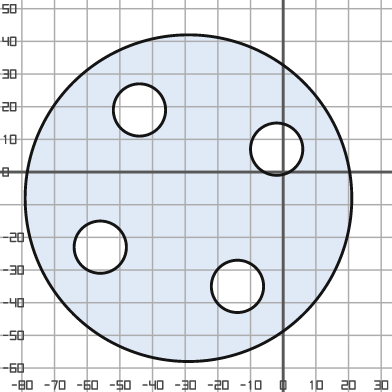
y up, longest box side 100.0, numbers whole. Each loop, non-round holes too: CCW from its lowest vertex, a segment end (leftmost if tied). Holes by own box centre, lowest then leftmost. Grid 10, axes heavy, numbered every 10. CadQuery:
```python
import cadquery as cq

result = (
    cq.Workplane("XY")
    .moveTo(-29.0, -8.0)
    .circle(50.0)
    .moveTo(-14.0, -35.0)
    .circle(8.0)
    .moveTo(-56.0, -23.0)
    .circle(8.0)
    .moveTo(-2.0, 7.0)
    .circle(8.0)
    .moveTo(-44.0, 19.0)
    .circle(8.0)
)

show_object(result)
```